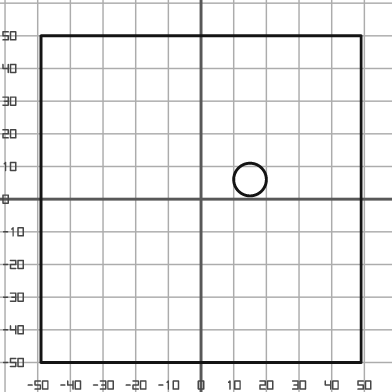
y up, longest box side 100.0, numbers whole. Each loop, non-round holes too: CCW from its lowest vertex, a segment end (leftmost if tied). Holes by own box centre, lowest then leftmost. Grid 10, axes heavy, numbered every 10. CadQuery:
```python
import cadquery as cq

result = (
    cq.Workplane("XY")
    .moveTo(-49.0, -50.0)
    .lineTo(49.0, -50.0)
    .lineTo(49.0, 50.0)
    .lineTo(-49.0, 50.0)
    .close()
    .moveTo(15.0, 6.0)
    .circle(5.0)
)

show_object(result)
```